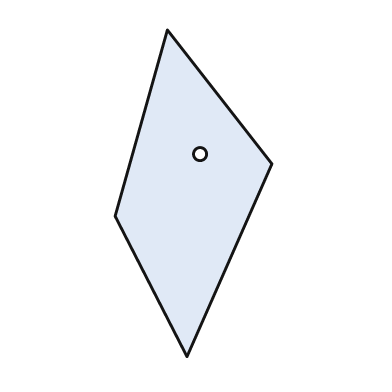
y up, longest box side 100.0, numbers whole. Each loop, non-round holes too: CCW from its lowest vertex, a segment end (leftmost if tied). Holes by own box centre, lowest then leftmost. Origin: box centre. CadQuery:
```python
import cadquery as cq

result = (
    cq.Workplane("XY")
    .moveTo(-2.0, -50.0)
    .lineTo(24.0, 9.0)
    .lineTo(-8.0, 50.0)
    .lineTo(-24.0, -7.0)
    .close()
    .moveTo(2.0, 12.0)
    .circle(2.0)
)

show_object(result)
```